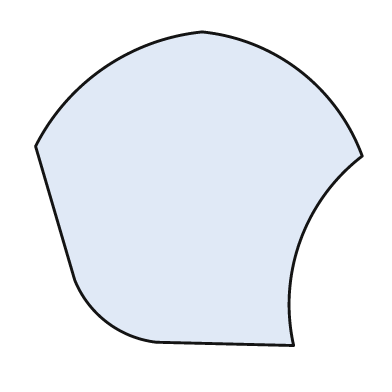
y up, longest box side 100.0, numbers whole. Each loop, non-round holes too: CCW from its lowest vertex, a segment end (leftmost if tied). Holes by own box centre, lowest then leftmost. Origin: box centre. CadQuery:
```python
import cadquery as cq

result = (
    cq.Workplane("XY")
    .moveTo(29.0, -48.0)
    .threePointArc((31.0, -16.0), (50.0, 10.0))
    .threePointArc((31.0, 36.0), (1.0, 48.0))
    .threePointArc((-29.0, 37.0), (-50.0, 13.0))
    .lineTo(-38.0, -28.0)
    .threePointArc((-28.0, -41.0), (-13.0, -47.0))
    .close()
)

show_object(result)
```